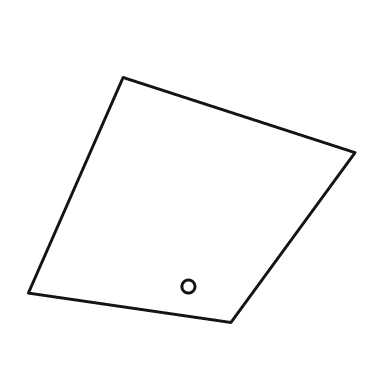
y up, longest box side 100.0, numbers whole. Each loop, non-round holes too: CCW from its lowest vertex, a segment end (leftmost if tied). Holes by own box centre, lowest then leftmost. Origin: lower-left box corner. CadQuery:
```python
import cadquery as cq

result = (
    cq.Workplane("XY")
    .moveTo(62.0, 0.0)
    .lineTo(100.0, 52.0)
    .lineTo(29.0, 75.0)
    .lineTo(0.0, 9.0)
    .close()
    .moveTo(49.0, 11.0)
    .circle(2.0)
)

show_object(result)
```